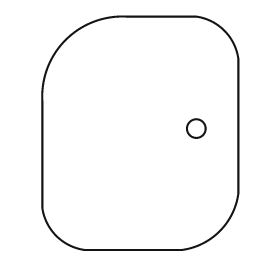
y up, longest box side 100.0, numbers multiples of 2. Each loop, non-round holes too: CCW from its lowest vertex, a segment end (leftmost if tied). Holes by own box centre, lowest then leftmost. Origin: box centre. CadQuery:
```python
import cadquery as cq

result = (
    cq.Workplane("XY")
    .moveTo(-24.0, -50.0)
    .lineTo(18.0, -50.0)
    .threePointArc((34.0, -42.0), (42.0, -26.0))
    .lineTo(42.0, 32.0)
    .threePointArc((36.0, 44.0), (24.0, 50.0))
    .lineTo(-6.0, 50.0)
    .threePointArc((-32.0, 40.0), (-42.0, 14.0))
    .lineTo(-42.0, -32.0)
    .threePointArc((-36.0, -44.0), (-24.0, -50.0))
    .close()
    .moveTo(24.0, 2.0)
    .circle(4.0)
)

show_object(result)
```